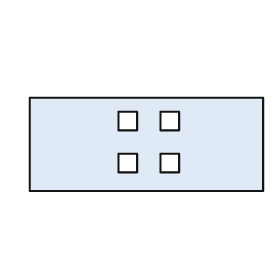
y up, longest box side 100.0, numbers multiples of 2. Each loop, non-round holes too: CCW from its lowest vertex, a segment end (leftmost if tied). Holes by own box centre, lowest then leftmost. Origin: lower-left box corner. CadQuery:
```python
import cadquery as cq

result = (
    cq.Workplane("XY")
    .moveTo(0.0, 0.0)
    .lineTo(100.0, 0.0)
    .lineTo(100.0, 40.0)
    .lineTo(0.0, 40.0)
    .close()
    .moveTo(38.0, 8.0)
    .lineTo(46.0, 8.0)
    .lineTo(46.0, 16.0)
    .lineTo(38.0, 16.0)
    .close()
    .moveTo(56.0, 8.0)
    .lineTo(64.0, 8.0)
    .lineTo(64.0, 16.0)
    .lineTo(56.0, 16.0)
    .close()
    .moveTo(38.0, 26.0)
    .lineTo(46.0, 26.0)
    .lineTo(46.0, 34.0)
    .lineTo(38.0, 34.0)
    .close()
    .moveTo(56.0, 26.0)
    .lineTo(64.0, 26.0)
    .lineTo(64.0, 34.0)
    .lineTo(56.0, 34.0)
    .close()
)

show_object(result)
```